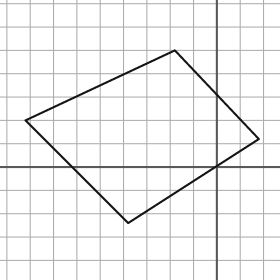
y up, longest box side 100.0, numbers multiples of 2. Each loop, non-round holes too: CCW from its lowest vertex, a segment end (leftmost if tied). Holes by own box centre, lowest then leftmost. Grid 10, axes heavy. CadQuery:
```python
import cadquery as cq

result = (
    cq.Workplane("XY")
    .moveTo(-38.0, -24.0)
    .lineTo(18.0, 12.0)
    .lineTo(-18.0, 50.0)
    .lineTo(-82.0, 20.0)
    .close()
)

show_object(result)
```